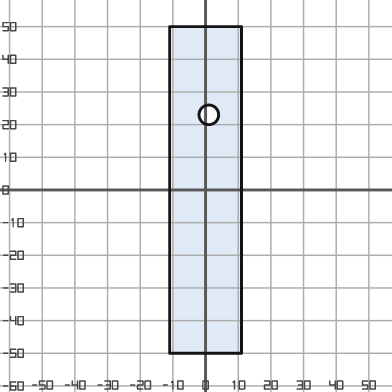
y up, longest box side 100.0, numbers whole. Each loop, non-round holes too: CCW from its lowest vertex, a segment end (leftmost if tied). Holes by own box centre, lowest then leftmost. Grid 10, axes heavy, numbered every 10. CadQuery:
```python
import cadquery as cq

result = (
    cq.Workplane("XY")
    .moveTo(-11.0, -50.0)
    .lineTo(11.0, -50.0)
    .lineTo(11.0, 50.0)
    .lineTo(-11.0, 50.0)
    .close()
    .moveTo(1.0, 23.0)
    .circle(3.0)
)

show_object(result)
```